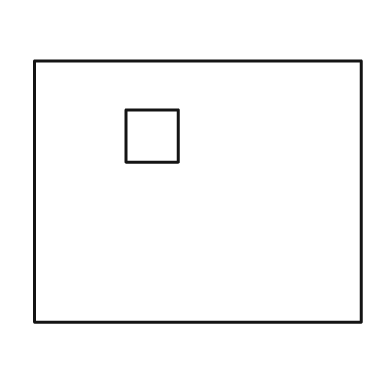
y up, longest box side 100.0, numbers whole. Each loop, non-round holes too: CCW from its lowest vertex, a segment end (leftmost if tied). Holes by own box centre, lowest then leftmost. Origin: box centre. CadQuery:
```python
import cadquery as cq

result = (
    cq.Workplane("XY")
    .moveTo(-50.0, -40.0)
    .lineTo(50.0, -40.0)
    .lineTo(50.0, 40.0)
    .lineTo(-50.0, 40.0)
    .close()
    .moveTo(-22.0, 9.0)
    .lineTo(-6.0, 9.0)
    .lineTo(-6.0, 25.0)
    .lineTo(-22.0, 25.0)
    .close()
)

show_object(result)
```